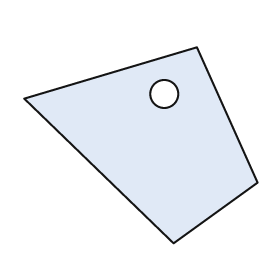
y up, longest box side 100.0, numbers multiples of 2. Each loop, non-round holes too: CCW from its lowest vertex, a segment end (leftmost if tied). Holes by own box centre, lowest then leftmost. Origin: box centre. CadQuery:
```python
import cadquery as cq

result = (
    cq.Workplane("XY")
    .moveTo(14.0, -42.0)
    .lineTo(50.0, -16.0)
    .lineTo(24.0, 42.0)
    .lineTo(-50.0, 20.0)
    .close()
    .moveTo(10.0, 22.0)
    .circle(6.0)
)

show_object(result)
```